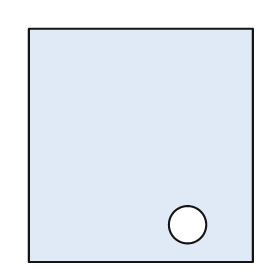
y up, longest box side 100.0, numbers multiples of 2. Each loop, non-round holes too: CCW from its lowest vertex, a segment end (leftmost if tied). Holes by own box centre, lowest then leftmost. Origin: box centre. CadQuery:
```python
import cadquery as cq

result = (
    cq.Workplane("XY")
    .moveTo(-48.0, -50.0)
    .lineTo(48.0, -50.0)
    .lineTo(48.0, 50.0)
    .lineTo(-48.0, 50.0)
    .close()
    .moveTo(20.0, -34.0)
    .circle(8.0)
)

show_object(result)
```